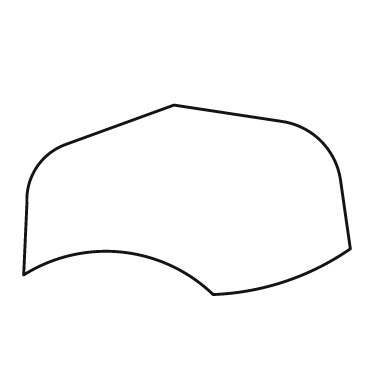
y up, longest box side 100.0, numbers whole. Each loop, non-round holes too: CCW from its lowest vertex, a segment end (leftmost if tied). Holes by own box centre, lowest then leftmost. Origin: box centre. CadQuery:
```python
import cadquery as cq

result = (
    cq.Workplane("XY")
    .moveTo(8.0, -29.0)
    .threePointArc((30.0, -25.0), (50.0, -15.0))
    .lineTo(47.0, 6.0)
    .threePointArc((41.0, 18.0), (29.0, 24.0))
    .lineTo(-4.0, 29.0)
    .lineTo(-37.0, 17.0)
    .threePointArc((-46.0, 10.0), (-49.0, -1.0))
    .lineTo(-50.0, -23.0)
    .threePointArc((-20.0, -16.0), (8.0, -29.0))
    .close()
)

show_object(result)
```